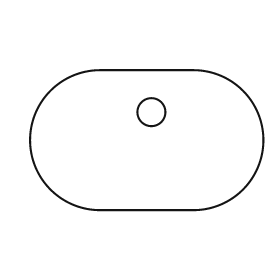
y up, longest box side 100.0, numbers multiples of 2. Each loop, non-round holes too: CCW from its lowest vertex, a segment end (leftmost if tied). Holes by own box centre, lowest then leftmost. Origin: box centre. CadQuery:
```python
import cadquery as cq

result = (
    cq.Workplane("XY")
    .moveTo(-20.0, -30.0)
    .lineTo(20.0, -30.0)
    .threePointArc((50.0, 0.0), (20.0, 30.0))
    .lineTo(-20.0, 30.0)
    .threePointArc((-50.0, 0.0), (-20.0, -30.0))
    .close()
    .moveTo(2.0, 12.0)
    .circle(6.0)
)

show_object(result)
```